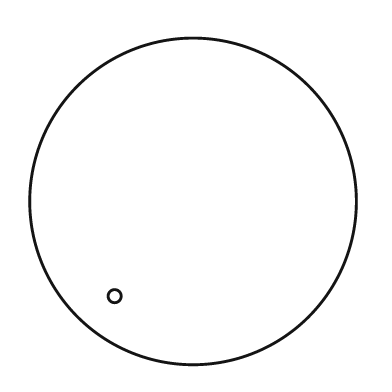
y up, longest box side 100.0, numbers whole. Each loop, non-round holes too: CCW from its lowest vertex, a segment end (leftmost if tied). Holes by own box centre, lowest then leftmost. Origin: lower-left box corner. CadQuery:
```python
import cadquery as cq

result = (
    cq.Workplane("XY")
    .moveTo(50.0, 50.0)
    .circle(50.0)
    .moveTo(26.0, 21.0)
    .circle(2.0)
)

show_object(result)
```